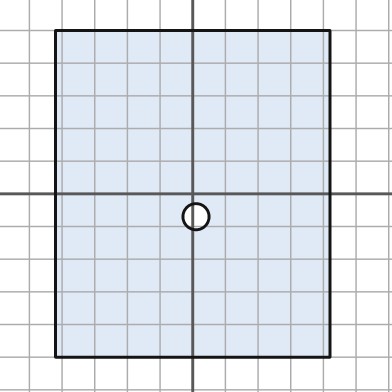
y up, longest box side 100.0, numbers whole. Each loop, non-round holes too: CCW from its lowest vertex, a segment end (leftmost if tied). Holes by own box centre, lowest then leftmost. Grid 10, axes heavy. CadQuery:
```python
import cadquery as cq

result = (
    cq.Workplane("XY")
    .moveTo(-42.0, -50.0)
    .lineTo(42.0, -50.0)
    .lineTo(42.0, 50.0)
    .lineTo(-42.0, 50.0)
    .close()
    .moveTo(1.0, -7.0)
    .circle(4.0)
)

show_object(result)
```